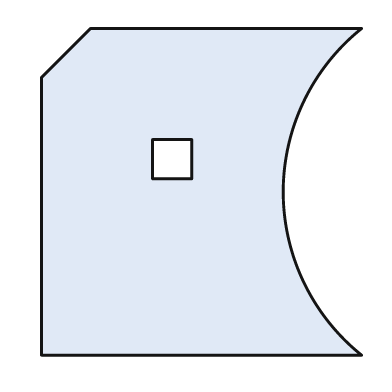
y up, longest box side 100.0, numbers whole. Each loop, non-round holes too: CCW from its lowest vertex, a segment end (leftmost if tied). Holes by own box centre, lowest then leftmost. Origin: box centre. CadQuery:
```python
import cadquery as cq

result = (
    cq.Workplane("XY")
    .moveTo(-49.0, -50.0)
    .lineTo(49.0, -50.0)
    .threePointArc((25.0, 0.0), (49.0, 50.0))
    .lineTo(-34.0, 50.0)
    .lineTo(-49.0, 35.0)
    .close()
    .moveTo(-15.0, 4.0)
    .lineTo(-3.0, 4.0)
    .lineTo(-3.0, 16.0)
    .lineTo(-15.0, 16.0)
    .close()
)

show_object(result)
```